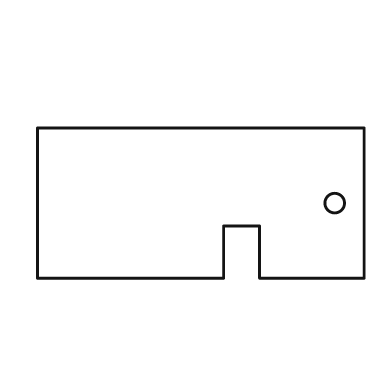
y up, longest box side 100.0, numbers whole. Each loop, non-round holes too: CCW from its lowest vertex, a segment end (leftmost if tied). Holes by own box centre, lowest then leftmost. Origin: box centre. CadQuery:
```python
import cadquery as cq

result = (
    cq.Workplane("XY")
    .moveTo(-50.0, -23.0)
    .lineTo(7.0, -23.0)
    .lineTo(7.0, -7.0)
    .lineTo(18.0, -7.0)
    .lineTo(18.0, -23.0)
    .lineTo(50.0, -23.0)
    .lineTo(50.0, 23.0)
    .lineTo(-50.0, 23.0)
    .close()
    .moveTo(41.0, 0.0)
    .circle(3.0)
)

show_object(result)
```